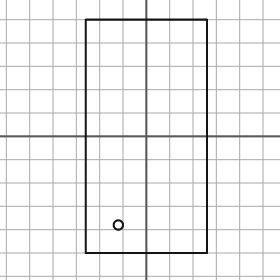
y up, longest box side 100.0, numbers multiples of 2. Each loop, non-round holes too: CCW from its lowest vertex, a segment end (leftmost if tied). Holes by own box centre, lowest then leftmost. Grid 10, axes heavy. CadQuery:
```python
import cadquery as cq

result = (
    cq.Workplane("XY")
    .moveTo(-26.0, -50.0)
    .lineTo(26.0, -50.0)
    .lineTo(26.0, 50.0)
    .lineTo(-26.0, 50.0)
    .close()
    .moveTo(-12.0, -38.0)
    .circle(2.0)
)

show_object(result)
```